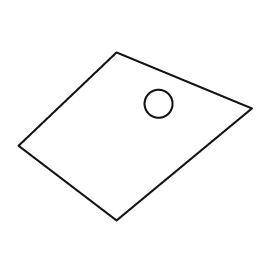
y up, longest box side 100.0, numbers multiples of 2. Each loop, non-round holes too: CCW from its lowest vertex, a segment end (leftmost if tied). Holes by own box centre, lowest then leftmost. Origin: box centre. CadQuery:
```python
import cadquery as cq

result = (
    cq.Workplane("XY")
    .moveTo(-8.0, -36.0)
    .lineTo(50.0, 12.0)
    .lineTo(-8.0, 36.0)
    .lineTo(-50.0, -4.0)
    .close()
    .moveTo(10.0, 14.0)
    .circle(6.0)
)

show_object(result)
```